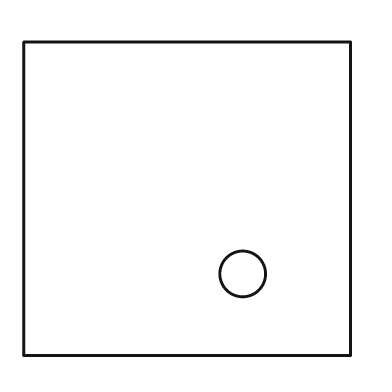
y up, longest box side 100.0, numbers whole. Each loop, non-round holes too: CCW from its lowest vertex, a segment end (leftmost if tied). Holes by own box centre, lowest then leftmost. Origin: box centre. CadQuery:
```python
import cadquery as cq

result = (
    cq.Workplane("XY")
    .moveTo(-50.0, -48.0)
    .lineTo(50.0, -48.0)
    .lineTo(50.0, 48.0)
    .lineTo(-50.0, 48.0)
    .close()
    .moveTo(17.0, -23.0)
    .circle(7.0)
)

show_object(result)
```